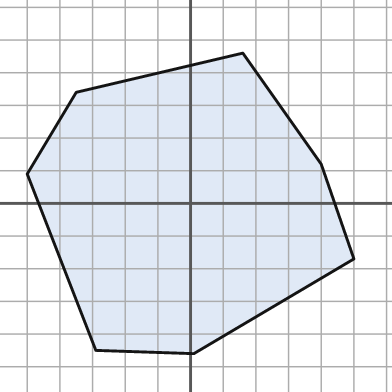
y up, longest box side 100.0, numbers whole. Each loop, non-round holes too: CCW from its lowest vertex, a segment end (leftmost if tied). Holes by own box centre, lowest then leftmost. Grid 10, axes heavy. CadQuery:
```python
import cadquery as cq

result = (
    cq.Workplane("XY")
    .moveTo(1.0, -46.0)
    .lineTo(50.0, -17.0)
    .lineTo(40.0, 12.0)
    .lineTo(16.0, 46.0)
    .lineTo(-35.0, 34.0)
    .lineTo(-50.0, 9.0)
    .lineTo(-29.0, -45.0)
    .close()
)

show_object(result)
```